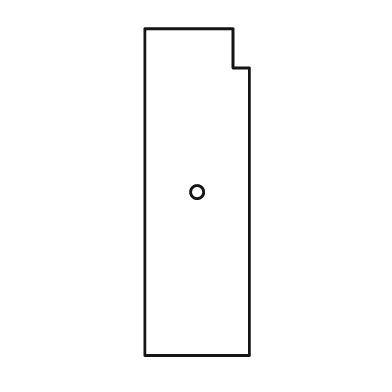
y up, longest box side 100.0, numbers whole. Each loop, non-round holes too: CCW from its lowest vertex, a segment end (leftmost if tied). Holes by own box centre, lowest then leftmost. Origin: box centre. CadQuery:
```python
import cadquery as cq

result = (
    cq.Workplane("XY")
    .moveTo(-16.0, -50.0)
    .lineTo(16.0, -50.0)
    .lineTo(16.0, 38.0)
    .lineTo(11.0, 38.0)
    .lineTo(11.0, 50.0)
    .lineTo(-16.0, 50.0)
    .close()
    .moveTo(0.0, 0.0)
    .circle(2.0)
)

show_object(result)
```